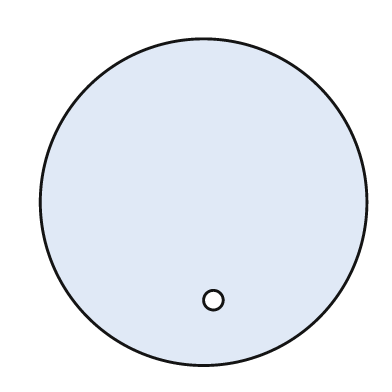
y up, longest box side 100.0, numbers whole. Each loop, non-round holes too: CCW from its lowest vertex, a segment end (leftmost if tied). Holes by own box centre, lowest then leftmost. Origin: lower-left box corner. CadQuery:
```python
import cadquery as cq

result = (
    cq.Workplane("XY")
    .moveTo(50.0, 50.0)
    .circle(50.0)
    .moveTo(53.0, 20.0)
    .circle(3.0)
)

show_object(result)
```